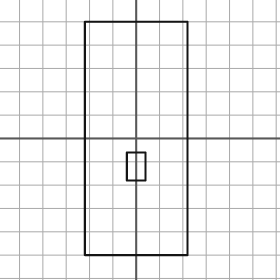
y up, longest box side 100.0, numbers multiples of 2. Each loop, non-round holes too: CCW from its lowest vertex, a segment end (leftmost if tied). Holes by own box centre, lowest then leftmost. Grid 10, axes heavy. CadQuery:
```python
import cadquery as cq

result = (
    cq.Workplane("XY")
    .moveTo(-22.0, -50.0)
    .lineTo(22.0, -50.0)
    .lineTo(22.0, 50.0)
    .lineTo(-22.0, 50.0)
    .close()
    .moveTo(-4.0, -18.0)
    .lineTo(4.0, -18.0)
    .lineTo(4.0, -6.0)
    .lineTo(-4.0, -6.0)
    .close()
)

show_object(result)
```